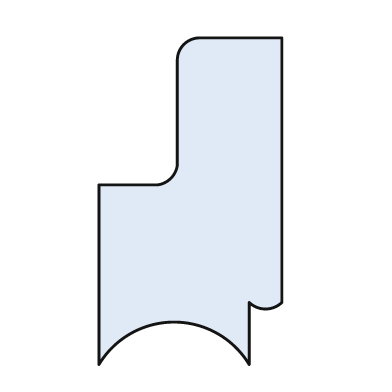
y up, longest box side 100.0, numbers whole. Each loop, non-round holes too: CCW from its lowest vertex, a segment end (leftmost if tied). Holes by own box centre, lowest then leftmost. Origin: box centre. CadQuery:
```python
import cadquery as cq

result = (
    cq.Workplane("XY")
    .moveTo(-28.0, -50.0)
    .threePointArc((-5.0, -37.0), (18.0, -50.0))
    .lineTo(18.0, -31.0)
    .threePointArc((23.0, -33.0), (28.0, -31.0))
    .lineTo(28.0, 50.0)
    .lineTo(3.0, 50.0)
    .threePointArc((-2.0, 48.0), (-4.0, 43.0))
    .lineTo(-4.0, 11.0)
    .threePointArc((-6.0, 7.0), (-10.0, 5.0))
    .lineTo(-28.0, 5.0)
    .close()
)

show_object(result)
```